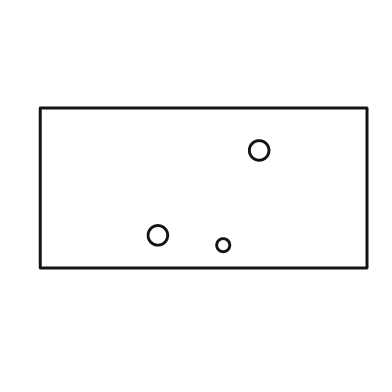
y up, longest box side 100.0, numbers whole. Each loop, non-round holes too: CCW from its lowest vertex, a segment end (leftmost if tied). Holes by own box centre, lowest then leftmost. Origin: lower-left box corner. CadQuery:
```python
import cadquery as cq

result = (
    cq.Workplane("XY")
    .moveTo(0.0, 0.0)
    .lineTo(100.0, 0.0)
    .lineTo(100.0, 49.0)
    .lineTo(0.0, 49.0)
    .close()
    .moveTo(56.0, 7.0)
    .circle(2.0)
    .moveTo(36.0, 10.0)
    .circle(3.0)
    .moveTo(67.0, 36.0)
    .circle(3.0)
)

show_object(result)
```